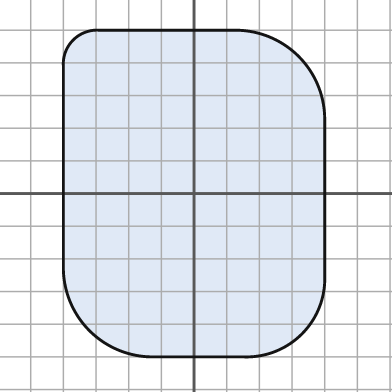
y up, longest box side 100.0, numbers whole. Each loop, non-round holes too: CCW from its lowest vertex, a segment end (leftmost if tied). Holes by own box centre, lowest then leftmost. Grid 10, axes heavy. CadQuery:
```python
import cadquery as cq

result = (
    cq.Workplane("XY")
    .moveTo(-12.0, -50.0)
    .lineTo(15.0, -50.0)
    .threePointArc((33.0, -43.0), (40.0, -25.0))
    .lineTo(40.0, 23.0)
    .threePointArc((32.0, 42.0), (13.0, 50.0))
    .lineTo(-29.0, 50.0)
    .threePointArc((-37.0, 47.0), (-40.0, 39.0))
    .lineTo(-40.0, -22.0)
    .threePointArc((-32.0, -42.0), (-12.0, -50.0))
    .close()
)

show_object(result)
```